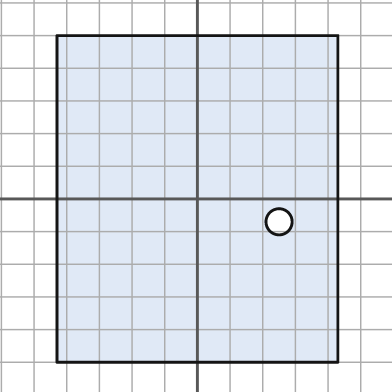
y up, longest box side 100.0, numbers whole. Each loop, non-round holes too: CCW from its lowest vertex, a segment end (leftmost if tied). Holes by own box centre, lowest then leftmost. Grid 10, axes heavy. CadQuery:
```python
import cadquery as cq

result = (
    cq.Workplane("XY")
    .moveTo(-43.0, -50.0)
    .lineTo(43.0, -50.0)
    .lineTo(43.0, 50.0)
    .lineTo(-43.0, 50.0)
    .close()
    .moveTo(25.0, -7.0)
    .circle(4.0)
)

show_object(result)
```